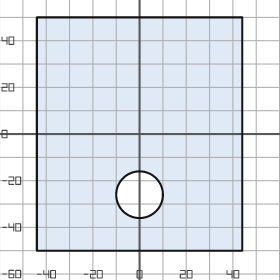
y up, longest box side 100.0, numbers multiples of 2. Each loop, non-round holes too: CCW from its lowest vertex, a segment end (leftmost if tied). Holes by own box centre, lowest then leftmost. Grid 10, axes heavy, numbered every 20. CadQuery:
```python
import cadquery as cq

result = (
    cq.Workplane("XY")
    .moveTo(-44.0, -50.0)
    .lineTo(44.0, -50.0)
    .lineTo(44.0, 50.0)
    .lineTo(-44.0, 50.0)
    .close()
    .moveTo(0.0, -26.0)
    .circle(10.0)
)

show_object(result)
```